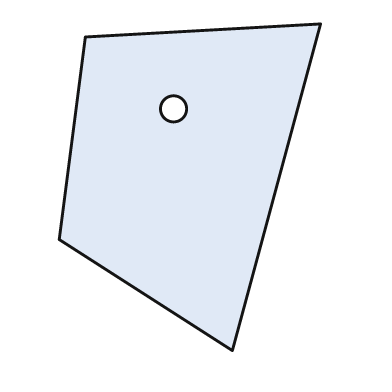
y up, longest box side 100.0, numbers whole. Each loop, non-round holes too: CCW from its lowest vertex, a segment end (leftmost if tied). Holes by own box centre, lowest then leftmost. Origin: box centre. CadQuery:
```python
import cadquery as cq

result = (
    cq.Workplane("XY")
    .moveTo(13.0, -50.0)
    .lineTo(40.0, 50.0)
    .lineTo(-32.0, 46.0)
    .lineTo(-40.0, -16.0)
    .close()
    .moveTo(-5.0, 24.0)
    .circle(4.0)
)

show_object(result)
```